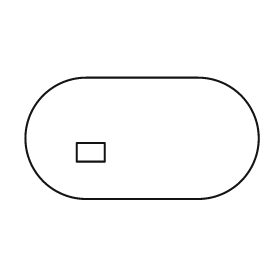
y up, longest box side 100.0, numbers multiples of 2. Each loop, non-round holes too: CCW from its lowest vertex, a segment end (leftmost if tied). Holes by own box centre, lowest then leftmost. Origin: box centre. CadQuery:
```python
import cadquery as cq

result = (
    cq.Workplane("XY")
    .moveTo(-24.0, -26.0)
    .lineTo(24.0, -26.0)
    .threePointArc((50.0, 0.0), (24.0, 26.0))
    .lineTo(-24.0, 26.0)
    .threePointArc((-50.0, 0.0), (-24.0, -26.0))
    .close()
    .moveTo(-28.0, -10.0)
    .lineTo(-16.0, -10.0)
    .lineTo(-16.0, -2.0)
    .lineTo(-28.0, -2.0)
    .close()
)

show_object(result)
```